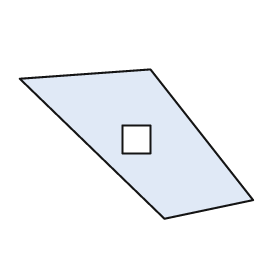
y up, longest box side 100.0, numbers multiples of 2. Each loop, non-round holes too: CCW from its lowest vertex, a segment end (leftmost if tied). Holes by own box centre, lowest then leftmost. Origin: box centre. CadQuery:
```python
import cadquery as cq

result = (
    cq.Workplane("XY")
    .moveTo(12.0, -32.0)
    .lineTo(50.0, -24.0)
    .lineTo(6.0, 32.0)
    .lineTo(-50.0, 28.0)
    .close()
    .moveTo(-6.0, -4.0)
    .lineTo(6.0, -4.0)
    .lineTo(6.0, 8.0)
    .lineTo(-6.0, 8.0)
    .close()
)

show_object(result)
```